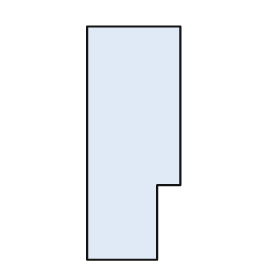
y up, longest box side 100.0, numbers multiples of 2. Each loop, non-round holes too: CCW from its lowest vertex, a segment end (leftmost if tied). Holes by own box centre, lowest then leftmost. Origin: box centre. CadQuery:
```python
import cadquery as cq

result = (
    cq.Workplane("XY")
    .moveTo(-20.0, -50.0)
    .lineTo(10.0, -50.0)
    .lineTo(10.0, -18.0)
    .lineTo(20.0, -18.0)
    .lineTo(20.0, 50.0)
    .lineTo(-20.0, 50.0)
    .close()
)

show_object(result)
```